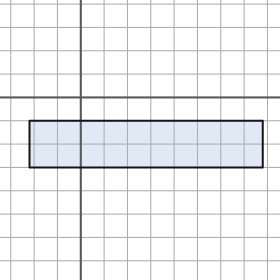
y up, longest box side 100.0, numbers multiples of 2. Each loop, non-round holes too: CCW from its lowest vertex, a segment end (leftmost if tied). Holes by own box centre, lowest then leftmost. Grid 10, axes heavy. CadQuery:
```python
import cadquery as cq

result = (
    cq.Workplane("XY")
    .moveTo(-22.0, -30.0)
    .lineTo(78.0, -30.0)
    .lineTo(78.0, -10.0)
    .lineTo(-22.0, -10.0)
    .close()
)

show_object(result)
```